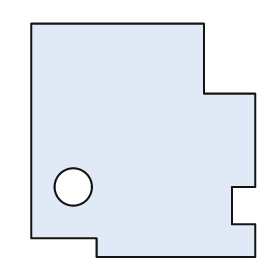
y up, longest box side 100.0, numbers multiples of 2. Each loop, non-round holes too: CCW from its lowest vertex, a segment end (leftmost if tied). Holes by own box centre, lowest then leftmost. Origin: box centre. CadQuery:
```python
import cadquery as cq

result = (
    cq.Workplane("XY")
    .moveTo(-20.0, -50.0)
    .lineTo(48.0, -50.0)
    .lineTo(48.0, -36.0)
    .lineTo(38.0, -36.0)
    .lineTo(38.0, -20.0)
    .lineTo(48.0, -20.0)
    .lineTo(48.0, 20.0)
    .lineTo(26.0, 20.0)
    .lineTo(26.0, 50.0)
    .lineTo(-48.0, 50.0)
    .lineTo(-48.0, -42.0)
    .lineTo(-20.0, -42.0)
    .close()
    .moveTo(-30.0, -20.0)
    .circle(8.0)
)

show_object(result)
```